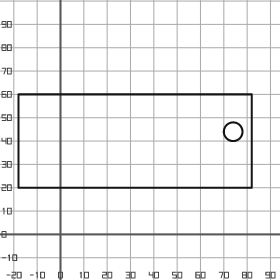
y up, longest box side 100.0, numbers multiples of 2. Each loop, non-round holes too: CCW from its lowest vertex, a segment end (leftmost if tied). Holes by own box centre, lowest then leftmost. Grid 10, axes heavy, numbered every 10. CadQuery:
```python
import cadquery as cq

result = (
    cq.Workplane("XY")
    .moveTo(-18.0, 20.0)
    .lineTo(82.0, 20.0)
    .lineTo(82.0, 60.0)
    .lineTo(-18.0, 60.0)
    .close()
    .moveTo(74.0, 44.0)
    .circle(4.0)
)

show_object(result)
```